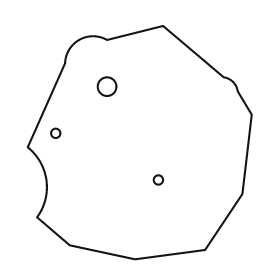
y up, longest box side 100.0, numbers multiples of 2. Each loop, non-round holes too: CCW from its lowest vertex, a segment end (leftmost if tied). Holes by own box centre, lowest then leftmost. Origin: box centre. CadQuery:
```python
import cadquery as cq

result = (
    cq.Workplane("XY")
    .moveTo(-2.0, -50.0)
    .lineTo(28.0, -46.0)
    .lineTo(44.0, -22.0)
    .lineTo(48.0, 12.0)
    .lineTo(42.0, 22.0)
    .threePointArc((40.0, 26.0), (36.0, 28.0))
    .lineTo(10.0, 50.0)
    .lineTo(-14.0, 44.0)
    .threePointArc((-26.0, 44.0), (-32.0, 34.0))
    .lineTo(-48.0, -2.0)
    .threePointArc((-40.0, -16.0), (-44.0, -32.0))
    .lineTo(-30.0, -44.0)
    .close()
    .moveTo(8.0, -16.0)
    .circle(2.0)
    .moveTo(-36.0, 4.0)
    .circle(2.0)
    .moveTo(-14.0, 24.0)
    .circle(4.0)
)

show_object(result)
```